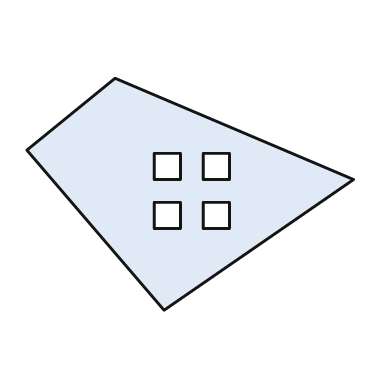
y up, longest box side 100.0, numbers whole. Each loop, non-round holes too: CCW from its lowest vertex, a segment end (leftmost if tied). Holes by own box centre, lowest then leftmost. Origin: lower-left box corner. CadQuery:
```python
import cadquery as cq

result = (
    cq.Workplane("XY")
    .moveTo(42.0, 0.0)
    .lineTo(100.0, 40.0)
    .lineTo(27.0, 71.0)
    .lineTo(0.0, 49.0)
    .close()
    .moveTo(39.0, 25.0)
    .lineTo(47.0, 25.0)
    .lineTo(47.0, 33.0)
    .lineTo(39.0, 33.0)
    .close()
    .moveTo(54.0, 25.0)
    .lineTo(62.0, 25.0)
    .lineTo(62.0, 33.0)
    .lineTo(54.0, 33.0)
    .close()
    .moveTo(39.0, 40.0)
    .lineTo(47.0, 40.0)
    .lineTo(47.0, 48.0)
    .lineTo(39.0, 48.0)
    .close()
    .moveTo(54.0, 40.0)
    .lineTo(62.0, 40.0)
    .lineTo(62.0, 48.0)
    .lineTo(54.0, 48.0)
    .close()
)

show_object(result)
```